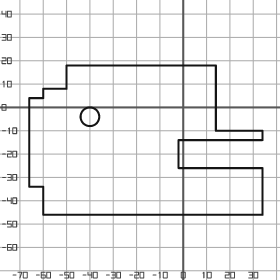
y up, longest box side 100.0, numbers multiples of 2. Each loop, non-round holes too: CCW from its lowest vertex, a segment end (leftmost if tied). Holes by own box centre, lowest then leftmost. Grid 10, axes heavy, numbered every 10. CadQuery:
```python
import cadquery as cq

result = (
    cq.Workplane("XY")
    .moveTo(-60.0, -46.0)
    .lineTo(34.0, -46.0)
    .lineTo(34.0, -26.0)
    .lineTo(-2.0, -26.0)
    .lineTo(-2.0, -14.0)
    .lineTo(34.0, -14.0)
    .lineTo(34.0, -10.0)
    .lineTo(14.0, -10.0)
    .lineTo(14.0, 18.0)
    .lineTo(-50.0, 18.0)
    .lineTo(-50.0, 8.0)
    .lineTo(-60.0, 8.0)
    .lineTo(-60.0, 4.0)
    .lineTo(-66.0, 4.0)
    .lineTo(-66.0, -34.0)
    .lineTo(-60.0, -34.0)
    .close()
    .moveTo(-40.0, -4.0)
    .circle(4.0)
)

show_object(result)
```